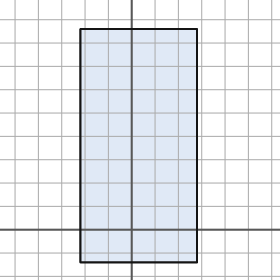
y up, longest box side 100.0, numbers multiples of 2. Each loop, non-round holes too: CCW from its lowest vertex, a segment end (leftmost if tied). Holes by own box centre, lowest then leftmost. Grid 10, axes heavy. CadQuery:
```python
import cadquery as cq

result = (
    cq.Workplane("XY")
    .moveTo(-22.0, -14.0)
    .lineTo(28.0, -14.0)
    .lineTo(28.0, 86.0)
    .lineTo(-22.0, 86.0)
    .close()
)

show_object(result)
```